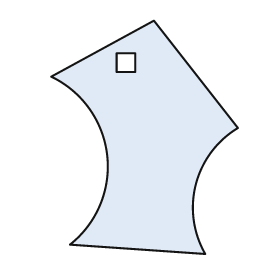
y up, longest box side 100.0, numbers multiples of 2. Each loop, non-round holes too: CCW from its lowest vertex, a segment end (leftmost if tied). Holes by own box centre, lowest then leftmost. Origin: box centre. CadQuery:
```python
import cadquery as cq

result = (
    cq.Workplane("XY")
    .moveTo(26.0, -50.0)
    .threePointArc((22.0, -20.0), (40.0, 4.0))
    .lineTo(4.0, 50.0)
    .lineTo(-40.0, 26.0)
    .threePointArc((-16.0, -8.0), (-32.0, -46.0))
    .close()
    .moveTo(-12.0, 28.0)
    .lineTo(-4.0, 28.0)
    .lineTo(-4.0, 36.0)
    .lineTo(-12.0, 36.0)
    .close()
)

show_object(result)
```